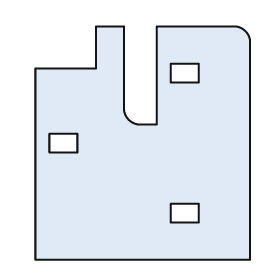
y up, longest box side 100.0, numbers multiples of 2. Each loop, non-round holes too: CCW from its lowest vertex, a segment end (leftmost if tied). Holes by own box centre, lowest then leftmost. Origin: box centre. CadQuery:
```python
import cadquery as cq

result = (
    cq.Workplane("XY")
    .moveTo(-46.0, -50.0)
    .lineTo(46.0, -50.0)
    .lineTo(46.0, 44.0)
    .threePointArc((44.0, 48.0), (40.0, 50.0))
    .lineTo(6.0, 50.0)
    .lineTo(6.0, 8.0)
    .lineTo(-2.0, 8.0)
    .threePointArc((-6.0, 10.0), (-8.0, 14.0))
    .lineTo(-8.0, 50.0)
    .lineTo(-20.0, 50.0)
    .lineTo(-20.0, 32.0)
    .lineTo(-46.0, 32.0)
    .close()
    .moveTo(12.0, -34.0)
    .lineTo(24.0, -34.0)
    .lineTo(24.0, -26.0)
    .lineTo(12.0, -26.0)
    .close()
    .moveTo(-40.0, -4.0)
    .lineTo(-28.0, -4.0)
    .lineTo(-28.0, 4.0)
    .lineTo(-40.0, 4.0)
    .close()
    .moveTo(12.0, 26.0)
    .lineTo(24.0, 26.0)
    .lineTo(24.0, 34.0)
    .lineTo(12.0, 34.0)
    .close()
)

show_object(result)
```